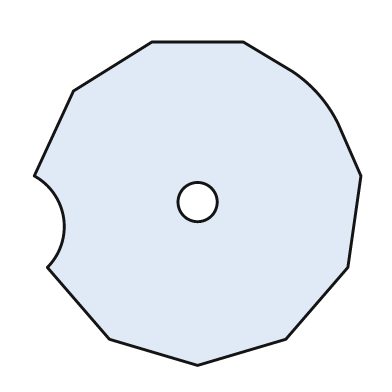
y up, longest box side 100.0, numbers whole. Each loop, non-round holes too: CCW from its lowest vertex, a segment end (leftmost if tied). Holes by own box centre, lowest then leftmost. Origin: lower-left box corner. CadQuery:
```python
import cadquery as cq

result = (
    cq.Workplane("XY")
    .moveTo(50.0, 0.0)
    .lineTo(77.0, 8.0)
    .lineTo(96.0, 30.0)
    .lineTo(100.0, 58.0)
    .lineTo(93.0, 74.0)
    .threePointArc((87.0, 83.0), (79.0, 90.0))
    .lineTo(64.0, 99.0)
    .lineTo(36.0, 99.0)
    .lineTo(12.0, 84.0)
    .lineTo(0.0, 58.0)
    .threePointArc((9.0, 45.0), (4.0, 30.0))
    .lineTo(23.0, 8.0)
    .close()
    .moveTo(50.0, 50.0)
    .circle(6.0)
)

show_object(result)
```